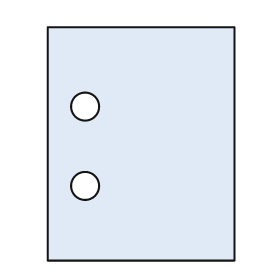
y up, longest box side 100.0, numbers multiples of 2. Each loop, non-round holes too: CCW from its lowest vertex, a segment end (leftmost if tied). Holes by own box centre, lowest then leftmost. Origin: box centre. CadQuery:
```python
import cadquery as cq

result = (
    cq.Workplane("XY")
    .moveTo(-40.0, -50.0)
    .lineTo(40.0, -50.0)
    .lineTo(40.0, 50.0)
    .lineTo(-40.0, 50.0)
    .close()
    .moveTo(-24.0, -18.0)
    .circle(6.0)
    .moveTo(-24.0, 16.0)
    .circle(6.0)
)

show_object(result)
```